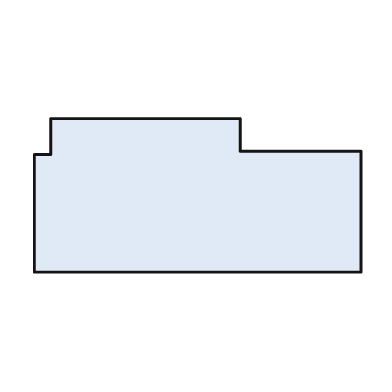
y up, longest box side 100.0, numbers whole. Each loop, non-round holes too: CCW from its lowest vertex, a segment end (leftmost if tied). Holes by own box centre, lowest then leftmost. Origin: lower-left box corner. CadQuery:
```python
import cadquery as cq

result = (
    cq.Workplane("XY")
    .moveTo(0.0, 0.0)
    .lineTo(100.0, 0.0)
    .lineTo(100.0, 37.0)
    .lineTo(63.0, 37.0)
    .lineTo(63.0, 47.0)
    .lineTo(5.0, 47.0)
    .lineTo(5.0, 36.0)
    .lineTo(0.0, 36.0)
    .close()
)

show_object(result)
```